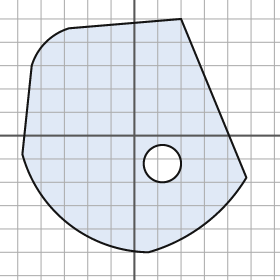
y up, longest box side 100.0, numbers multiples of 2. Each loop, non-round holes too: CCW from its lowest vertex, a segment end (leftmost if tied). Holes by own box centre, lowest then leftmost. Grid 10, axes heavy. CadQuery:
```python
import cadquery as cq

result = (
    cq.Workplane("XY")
    .moveTo(6.0, -50.0)
    .threePointArc((30.0, -38.0), (48.0, -18.0))
    .lineTo(20.0, 50.0)
    .lineTo(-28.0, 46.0)
    .threePointArc((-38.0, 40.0), (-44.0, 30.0))
    .lineTo(-48.0, -8.0)
    .threePointArc((-28.0, -38.0), (6.0, -50.0))
    .close()
    .moveTo(12.0, -12.0)
    .circle(8.0)
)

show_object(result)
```